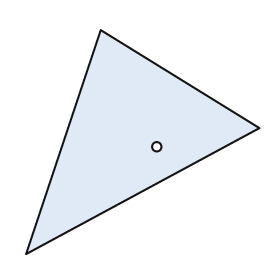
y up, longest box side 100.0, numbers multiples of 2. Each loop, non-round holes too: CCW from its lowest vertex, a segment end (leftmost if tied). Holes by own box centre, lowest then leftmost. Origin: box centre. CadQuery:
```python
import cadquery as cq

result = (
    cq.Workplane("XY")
    .moveTo(-50.0, -48.0)
    .lineTo(50.0, 6.0)
    .lineTo(-18.0, 48.0)
    .close()
    .moveTo(6.0, -2.0)
    .circle(2.0)
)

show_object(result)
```